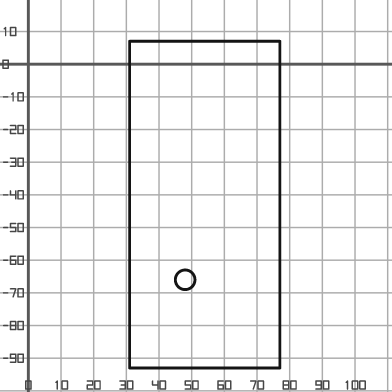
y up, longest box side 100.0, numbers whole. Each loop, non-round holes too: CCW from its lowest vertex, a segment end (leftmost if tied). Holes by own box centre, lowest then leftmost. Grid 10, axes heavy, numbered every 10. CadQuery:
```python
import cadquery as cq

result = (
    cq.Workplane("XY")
    .moveTo(31.0, -93.0)
    .lineTo(77.0, -93.0)
    .lineTo(77.0, 7.0)
    .lineTo(31.0, 7.0)
    .close()
    .moveTo(48.0, -66.0)
    .circle(3.0)
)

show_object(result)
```